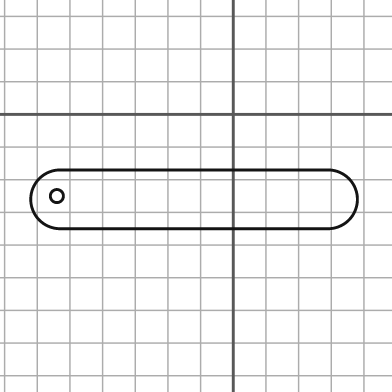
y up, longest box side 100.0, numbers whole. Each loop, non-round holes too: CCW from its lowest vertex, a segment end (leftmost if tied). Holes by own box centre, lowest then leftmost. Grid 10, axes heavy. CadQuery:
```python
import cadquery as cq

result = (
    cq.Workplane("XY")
    .moveTo(-53.0, -35.0)
    .lineTo(29.0, -35.0)
    .threePointArc((38.0, -26.0), (29.0, -17.0))
    .lineTo(-53.0, -17.0)
    .threePointArc((-62.0, -26.0), (-53.0, -35.0))
    .close()
    .moveTo(-54.0, -25.0)
    .circle(2.0)
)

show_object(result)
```